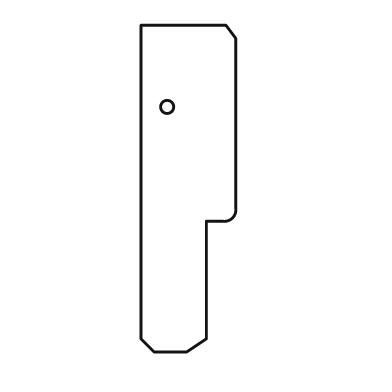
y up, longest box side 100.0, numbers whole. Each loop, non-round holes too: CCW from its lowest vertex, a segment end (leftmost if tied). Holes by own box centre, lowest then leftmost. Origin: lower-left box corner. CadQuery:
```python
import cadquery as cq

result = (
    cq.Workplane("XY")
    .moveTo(4.0, 0.0)
    .lineTo(14.0, 0.0)
    .lineTo(20.0, 4.0)
    .lineTo(20.0, 40.0)
    .lineTo(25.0, 40.0)
    .threePointArc((28.0, 41.0), (29.0, 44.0))
    .lineTo(29.0, 96.0)
    .lineTo(26.0, 100.0)
    .lineTo(0.0, 100.0)
    .lineTo(0.0, 4.0)
    .close()
    .moveTo(8.0, 75.0)
    .circle(2.0)
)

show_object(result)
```